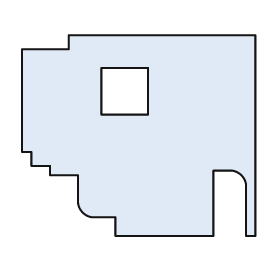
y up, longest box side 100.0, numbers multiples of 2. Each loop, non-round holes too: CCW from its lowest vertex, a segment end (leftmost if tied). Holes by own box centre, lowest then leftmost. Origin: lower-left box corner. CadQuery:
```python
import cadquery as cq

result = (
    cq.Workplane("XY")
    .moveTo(40.0, 0.0)
    .lineTo(82.0, 0.0)
    .lineTo(82.0, 28.0)
    .lineTo(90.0, 28.0)
    .threePointArc((94.0, 26.0), (96.0, 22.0))
    .lineTo(96.0, 0.0)
    .lineTo(100.0, 0.0)
    .lineTo(100.0, 86.0)
    .lineTo(20.0, 86.0)
    .lineTo(20.0, 80.0)
    .lineTo(0.0, 80.0)
    .lineTo(0.0, 36.0)
    .lineTo(4.0, 36.0)
    .lineTo(4.0, 30.0)
    .lineTo(12.0, 30.0)
    .lineTo(12.0, 26.0)
    .lineTo(24.0, 26.0)
    .lineTo(24.0, 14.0)
    .threePointArc((26.0, 10.0), (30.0, 8.0))
    .lineTo(40.0, 8.0)
    .close()
    .moveTo(34.0, 52.0)
    .lineTo(54.0, 52.0)
    .lineTo(54.0, 72.0)
    .lineTo(34.0, 72.0)
    .close()
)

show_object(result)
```